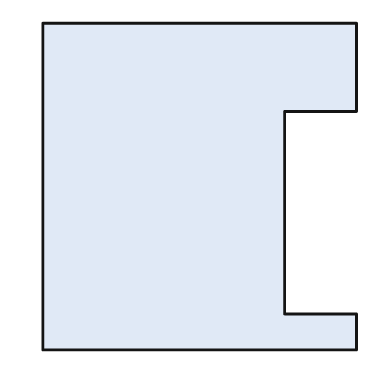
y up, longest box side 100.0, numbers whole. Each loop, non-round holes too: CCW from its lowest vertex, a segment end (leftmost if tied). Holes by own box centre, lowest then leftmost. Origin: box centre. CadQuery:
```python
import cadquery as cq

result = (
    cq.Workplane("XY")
    .moveTo(-48.0, -50.0)
    .lineTo(48.0, -50.0)
    .lineTo(48.0, -39.0)
    .lineTo(26.0, -39.0)
    .lineTo(26.0, 23.0)
    .lineTo(48.0, 23.0)
    .lineTo(48.0, 50.0)
    .lineTo(-48.0, 50.0)
    .close()
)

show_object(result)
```